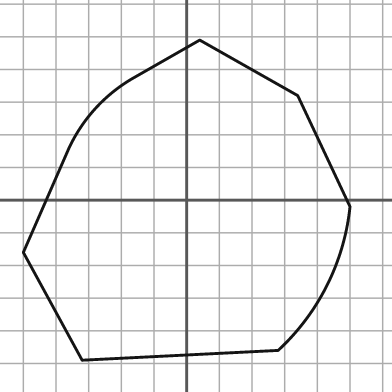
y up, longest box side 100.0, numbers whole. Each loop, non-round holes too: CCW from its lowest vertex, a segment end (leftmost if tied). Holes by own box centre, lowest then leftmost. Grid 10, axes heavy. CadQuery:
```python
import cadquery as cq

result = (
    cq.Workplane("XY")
    .moveTo(-32.0, -49.0)
    .lineTo(28.0, -46.0)
    .threePointArc((43.0, -26.0), (50.0, -2.0))
    .lineTo(34.0, 32.0)
    .lineTo(4.0, 49.0)
    .lineTo(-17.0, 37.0)
    .threePointArc((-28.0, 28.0), (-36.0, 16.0))
    .lineTo(-50.0, -16.0)
    .close()
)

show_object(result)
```